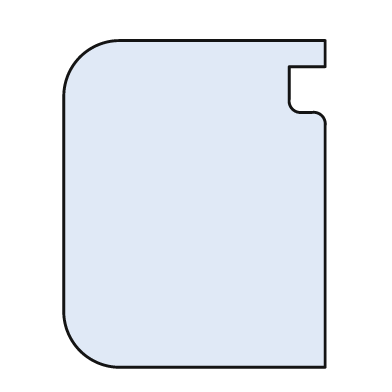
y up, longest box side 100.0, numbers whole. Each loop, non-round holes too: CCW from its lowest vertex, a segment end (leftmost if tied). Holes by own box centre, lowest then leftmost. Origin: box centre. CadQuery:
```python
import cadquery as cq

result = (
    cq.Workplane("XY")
    .moveTo(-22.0, -50.0)
    .lineTo(40.0, -50.0)
    .lineTo(40.0, 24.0)
    .threePointArc((39.0, 27.0), (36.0, 28.0))
    .lineTo(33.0, 28.0)
    .threePointArc((30.0, 29.0), (29.0, 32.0))
    .lineTo(29.0, 42.0)
    .lineTo(40.0, 42.0)
    .lineTo(40.0, 50.0)
    .lineTo(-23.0, 50.0)
    .threePointArc((-35.0, 45.0), (-40.0, 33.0))
    .lineTo(-40.0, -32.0)
    .threePointArc((-35.0, -45.0), (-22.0, -50.0))
    .close()
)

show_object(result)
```